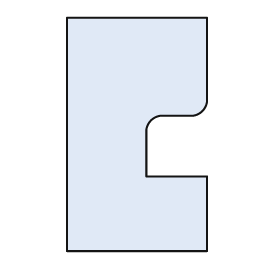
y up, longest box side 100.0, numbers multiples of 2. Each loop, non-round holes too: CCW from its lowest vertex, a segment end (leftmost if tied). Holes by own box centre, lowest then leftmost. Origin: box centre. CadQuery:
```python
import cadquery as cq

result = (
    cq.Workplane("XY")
    .moveTo(-30.0, -50.0)
    .lineTo(30.0, -50.0)
    .lineTo(30.0, -18.0)
    .lineTo(4.0, -18.0)
    .lineTo(4.0, 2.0)
    .threePointArc((6.0, 6.0), (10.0, 8.0))
    .lineTo(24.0, 8.0)
    .threePointArc((28.0, 10.0), (30.0, 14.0))
    .lineTo(30.0, 50.0)
    .lineTo(-30.0, 50.0)
    .close()
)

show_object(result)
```